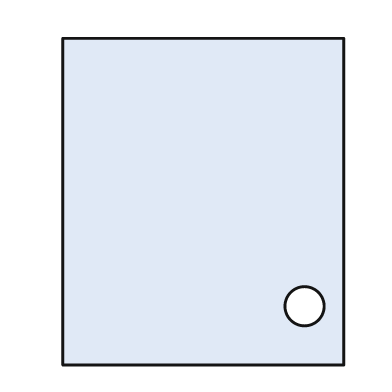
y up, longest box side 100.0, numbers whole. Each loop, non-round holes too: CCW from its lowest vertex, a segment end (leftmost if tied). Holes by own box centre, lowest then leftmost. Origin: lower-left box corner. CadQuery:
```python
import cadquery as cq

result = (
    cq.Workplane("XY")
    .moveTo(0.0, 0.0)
    .lineTo(86.0, 0.0)
    .lineTo(86.0, 100.0)
    .lineTo(0.0, 100.0)
    .close()
    .moveTo(74.0, 18.0)
    .circle(6.0)
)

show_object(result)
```